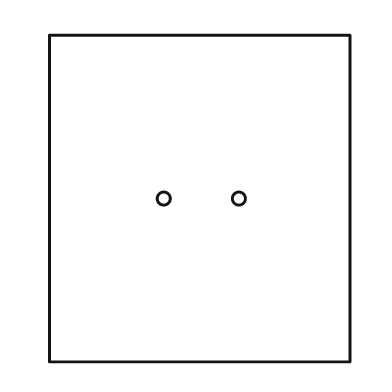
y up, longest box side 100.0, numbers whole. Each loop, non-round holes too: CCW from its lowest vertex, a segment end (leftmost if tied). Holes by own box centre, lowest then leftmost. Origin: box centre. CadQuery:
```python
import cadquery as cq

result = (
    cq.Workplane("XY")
    .moveTo(-46.0, -50.0)
    .lineTo(46.0, -50.0)
    .lineTo(46.0, 50.0)
    .lineTo(-46.0, 50.0)
    .close()
    .moveTo(-11.0, 0.0)
    .circle(2.0)
    .moveTo(12.0, 0.0)
    .circle(2.0)
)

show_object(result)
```